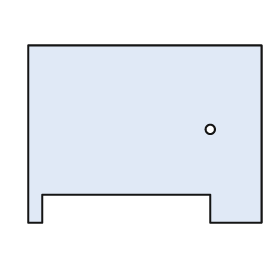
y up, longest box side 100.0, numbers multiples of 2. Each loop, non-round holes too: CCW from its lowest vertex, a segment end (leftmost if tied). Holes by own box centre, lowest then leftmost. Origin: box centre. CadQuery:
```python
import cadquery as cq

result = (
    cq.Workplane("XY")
    .moveTo(-50.0, -38.0)
    .lineTo(-44.0, -38.0)
    .lineTo(-44.0, -26.0)
    .lineTo(28.0, -26.0)
    .lineTo(28.0, -38.0)
    .lineTo(50.0, -38.0)
    .lineTo(50.0, 38.0)
    .lineTo(-50.0, 38.0)
    .close()
    .moveTo(28.0, 2.0)
    .circle(2.0)
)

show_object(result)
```